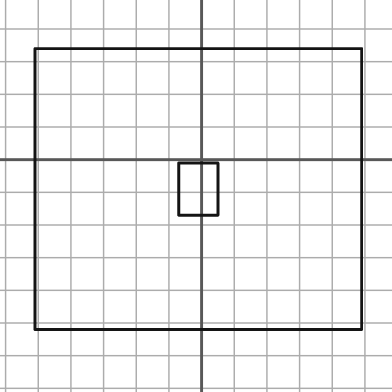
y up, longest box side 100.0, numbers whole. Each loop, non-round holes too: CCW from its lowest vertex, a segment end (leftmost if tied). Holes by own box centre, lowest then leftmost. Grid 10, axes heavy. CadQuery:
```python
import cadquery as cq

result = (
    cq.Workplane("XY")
    .moveTo(-51.0, -52.0)
    .lineTo(49.0, -52.0)
    .lineTo(49.0, 34.0)
    .lineTo(-51.0, 34.0)
    .close()
    .moveTo(-7.0, -17.0)
    .lineTo(5.0, -17.0)
    .lineTo(5.0, -1.0)
    .lineTo(-7.0, -1.0)
    .close()
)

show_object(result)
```